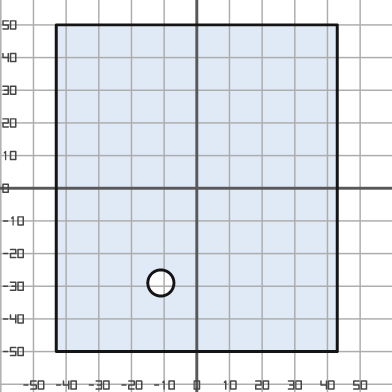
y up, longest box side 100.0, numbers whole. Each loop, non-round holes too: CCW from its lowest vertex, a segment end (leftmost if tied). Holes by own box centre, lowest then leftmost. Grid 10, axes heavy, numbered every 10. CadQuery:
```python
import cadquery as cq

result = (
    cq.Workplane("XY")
    .moveTo(-43.0, -50.0)
    .lineTo(43.0, -50.0)
    .lineTo(43.0, 50.0)
    .lineTo(-43.0, 50.0)
    .close()
    .moveTo(-11.0, -29.0)
    .circle(4.0)
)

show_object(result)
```